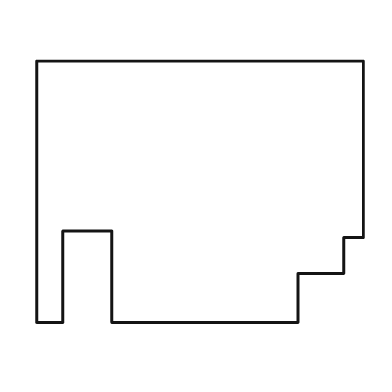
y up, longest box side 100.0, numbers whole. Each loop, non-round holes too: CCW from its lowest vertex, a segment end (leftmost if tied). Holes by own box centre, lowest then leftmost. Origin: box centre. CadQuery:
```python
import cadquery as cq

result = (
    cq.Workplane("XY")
    .moveTo(-50.0, -40.0)
    .lineTo(-42.0, -40.0)
    .lineTo(-42.0, -12.0)
    .lineTo(-27.0, -12.0)
    .lineTo(-27.0, -40.0)
    .lineTo(30.0, -40.0)
    .lineTo(30.0, -25.0)
    .lineTo(44.0, -25.0)
    .lineTo(44.0, -14.0)
    .lineTo(50.0, -14.0)
    .lineTo(50.0, 40.0)
    .lineTo(-50.0, 40.0)
    .close()
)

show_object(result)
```